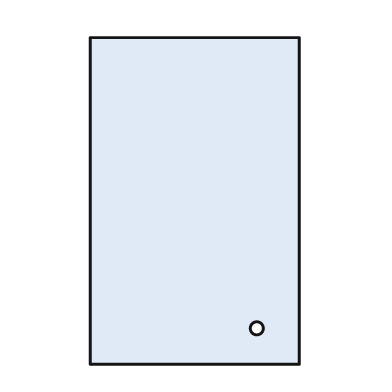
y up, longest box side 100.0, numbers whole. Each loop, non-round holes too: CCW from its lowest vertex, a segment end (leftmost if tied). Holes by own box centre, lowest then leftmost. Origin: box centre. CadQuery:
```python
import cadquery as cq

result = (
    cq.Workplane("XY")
    .moveTo(-32.0, -50.0)
    .lineTo(32.0, -50.0)
    .lineTo(32.0, 50.0)
    .lineTo(-32.0, 50.0)
    .close()
    .moveTo(19.0, -39.0)
    .circle(2.0)
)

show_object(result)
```